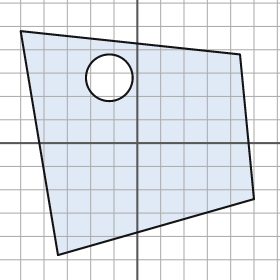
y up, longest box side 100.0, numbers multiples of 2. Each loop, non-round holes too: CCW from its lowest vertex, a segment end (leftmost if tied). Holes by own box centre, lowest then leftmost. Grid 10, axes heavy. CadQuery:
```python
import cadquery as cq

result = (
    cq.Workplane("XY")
    .moveTo(-34.0, -48.0)
    .lineTo(50.0, -24.0)
    .lineTo(44.0, 38.0)
    .lineTo(-50.0, 48.0)
    .close()
    .moveTo(-12.0, 28.0)
    .circle(10.0)
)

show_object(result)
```